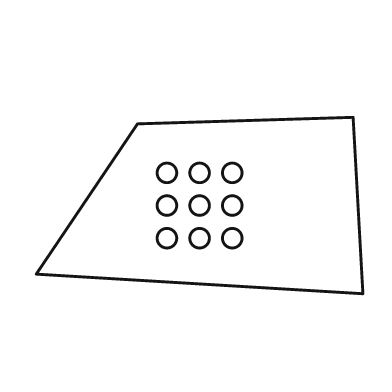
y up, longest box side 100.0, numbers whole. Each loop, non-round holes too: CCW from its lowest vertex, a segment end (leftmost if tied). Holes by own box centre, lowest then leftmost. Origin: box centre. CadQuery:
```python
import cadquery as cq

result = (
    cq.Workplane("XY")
    .moveTo(50.0, -27.0)
    .lineTo(47.0, 27.0)
    .lineTo(-19.0, 25.0)
    .lineTo(-50.0, -21.0)
    .close()
    .moveTo(-10.0, -10.0)
    .circle(3.0)
    .moveTo(0.0, -10.0)
    .circle(3.0)
    .moveTo(10.0, -10.0)
    .circle(3.0)
    .moveTo(-10.0, 0.0)
    .circle(3.0)
    .moveTo(0.0, 0.0)
    .circle(3.0)
    .moveTo(10.0, 0.0)
    .circle(3.0)
    .moveTo(-10.0, 10.0)
    .circle(3.0)
    .moveTo(0.0, 10.0)
    .circle(3.0)
    .moveTo(10.0, 10.0)
    .circle(3.0)
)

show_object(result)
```